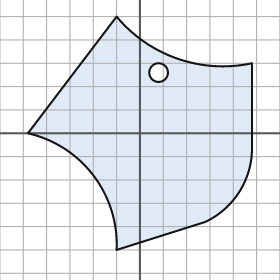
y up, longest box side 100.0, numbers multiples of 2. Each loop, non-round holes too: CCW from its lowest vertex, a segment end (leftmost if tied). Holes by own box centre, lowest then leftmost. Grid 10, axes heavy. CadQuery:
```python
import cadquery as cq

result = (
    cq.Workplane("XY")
    .moveTo(-10.0, -50.0)
    .lineTo(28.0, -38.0)
    .threePointArc((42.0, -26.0), (48.0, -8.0))
    .lineTo(48.0, 30.0)
    .threePointArc((16.0, 32.0), (-10.0, 50.0))
    .lineTo(-48.0, 0.0)
    .threePointArc((-20.0, -18.0), (-10.0, -50.0))
    .close()
    .moveTo(8.0, 26.0)
    .circle(4.0)
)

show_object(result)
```